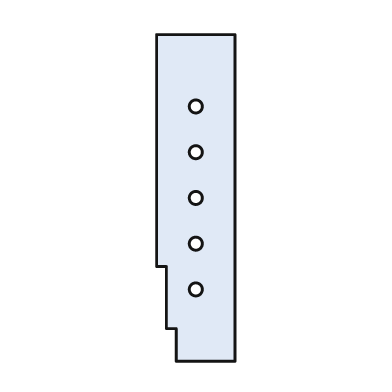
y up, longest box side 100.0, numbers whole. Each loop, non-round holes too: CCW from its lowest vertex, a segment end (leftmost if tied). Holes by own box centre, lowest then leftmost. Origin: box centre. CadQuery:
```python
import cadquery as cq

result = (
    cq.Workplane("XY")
    .moveTo(-6.0, -50.0)
    .lineTo(12.0, -50.0)
    .lineTo(12.0, 50.0)
    .lineTo(-12.0, 50.0)
    .lineTo(-12.0, -21.0)
    .lineTo(-9.0, -21.0)
    .lineTo(-9.0, -40.0)
    .lineTo(-6.0, -40.0)
    .close()
    .moveTo(0.0, -28.0)
    .circle(2.0)
    .moveTo(0.0, -14.0)
    .circle(2.0)
    .moveTo(0.0, 0.0)
    .circle(2.0)
    .moveTo(0.0, 14.0)
    .circle(2.0)
    .moveTo(0.0, 28.0)
    .circle(2.0)
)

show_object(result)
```